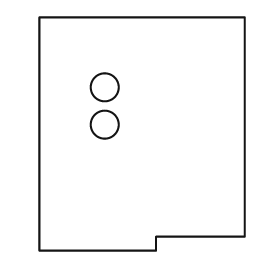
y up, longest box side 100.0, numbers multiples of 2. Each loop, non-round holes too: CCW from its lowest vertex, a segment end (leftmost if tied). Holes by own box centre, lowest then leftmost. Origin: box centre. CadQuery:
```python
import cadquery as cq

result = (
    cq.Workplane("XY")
    .moveTo(-44.0, -50.0)
    .lineTo(6.0, -50.0)
    .lineTo(6.0, -44.0)
    .lineTo(44.0, -44.0)
    .lineTo(44.0, 50.0)
    .lineTo(-44.0, 50.0)
    .close()
    .moveTo(-16.0, 4.0)
    .circle(6.0)
    .moveTo(-16.0, 20.0)
    .circle(6.0)
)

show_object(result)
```